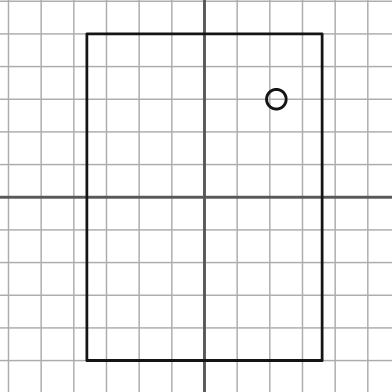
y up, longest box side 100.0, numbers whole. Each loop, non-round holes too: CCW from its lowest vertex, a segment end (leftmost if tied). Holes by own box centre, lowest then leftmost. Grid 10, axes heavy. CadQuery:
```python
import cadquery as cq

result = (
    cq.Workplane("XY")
    .moveTo(-36.0, -50.0)
    .lineTo(36.0, -50.0)
    .lineTo(36.0, 50.0)
    .lineTo(-36.0, 50.0)
    .close()
    .moveTo(22.0, 30.0)
    .circle(3.0)
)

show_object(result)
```